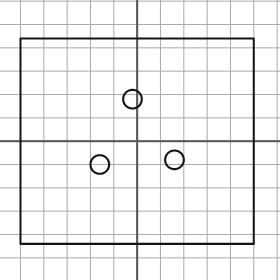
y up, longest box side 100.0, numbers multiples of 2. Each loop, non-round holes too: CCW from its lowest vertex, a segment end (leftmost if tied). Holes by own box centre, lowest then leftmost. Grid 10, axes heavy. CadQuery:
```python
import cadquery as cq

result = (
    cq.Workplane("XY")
    .moveTo(-50.0, -44.0)
    .lineTo(50.0, -44.0)
    .lineTo(50.0, 44.0)
    .lineTo(-50.0, 44.0)
    .close()
    .moveTo(-16.0, -10.0)
    .circle(4.0)
    .moveTo(16.0, -8.0)
    .circle(4.0)
    .moveTo(-2.0, 18.0)
    .circle(4.0)
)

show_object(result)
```